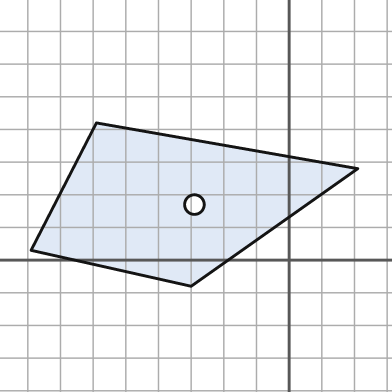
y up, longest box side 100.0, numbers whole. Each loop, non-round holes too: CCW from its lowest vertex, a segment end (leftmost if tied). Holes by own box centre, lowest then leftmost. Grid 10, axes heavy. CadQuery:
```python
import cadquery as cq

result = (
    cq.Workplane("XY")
    .moveTo(-30.0, -8.0)
    .lineTo(21.0, 28.0)
    .lineTo(-59.0, 42.0)
    .lineTo(-79.0, 3.0)
    .close()
    .moveTo(-29.0, 17.0)
    .circle(3.0)
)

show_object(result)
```